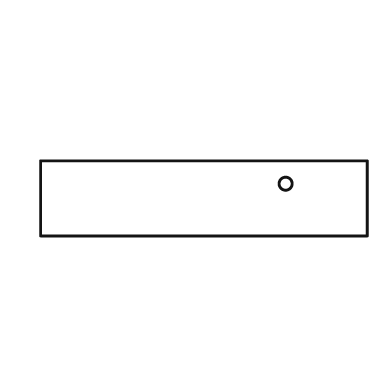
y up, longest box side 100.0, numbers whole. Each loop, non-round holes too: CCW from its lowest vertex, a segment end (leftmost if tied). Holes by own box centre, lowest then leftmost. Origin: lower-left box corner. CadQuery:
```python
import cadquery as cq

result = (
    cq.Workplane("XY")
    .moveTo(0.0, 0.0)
    .lineTo(100.0, 0.0)
    .lineTo(100.0, 23.0)
    .lineTo(0.0, 23.0)
    .close()
    .moveTo(75.0, 16.0)
    .circle(2.0)
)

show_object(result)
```